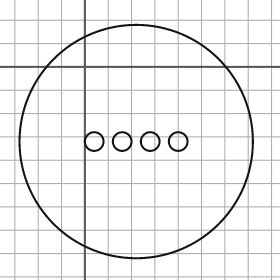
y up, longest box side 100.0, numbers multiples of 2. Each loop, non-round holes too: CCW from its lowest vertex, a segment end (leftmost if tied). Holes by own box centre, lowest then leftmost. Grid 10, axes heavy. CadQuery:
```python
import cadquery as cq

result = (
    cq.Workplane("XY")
    .moveTo(22.0, -32.0)
    .circle(50.0)
    .moveTo(4.0, -32.0)
    .circle(4.0)
    .moveTo(16.0, -32.0)
    .circle(4.0)
    .moveTo(28.0, -32.0)
    .circle(4.0)
    .moveTo(40.0, -32.0)
    .circle(4.0)
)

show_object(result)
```